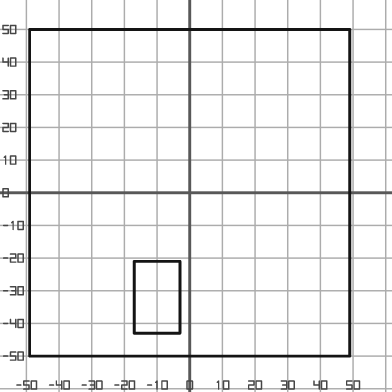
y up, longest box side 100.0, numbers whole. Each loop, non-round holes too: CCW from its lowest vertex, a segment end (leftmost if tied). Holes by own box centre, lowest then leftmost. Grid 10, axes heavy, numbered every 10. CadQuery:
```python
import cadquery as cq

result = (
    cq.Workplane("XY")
    .moveTo(-49.0, -50.0)
    .lineTo(49.0, -50.0)
    .lineTo(49.0, 50.0)
    .lineTo(-49.0, 50.0)
    .close()
    .moveTo(-17.0, -43.0)
    .lineTo(-3.0, -43.0)
    .lineTo(-3.0, -21.0)
    .lineTo(-17.0, -21.0)
    .close()
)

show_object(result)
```